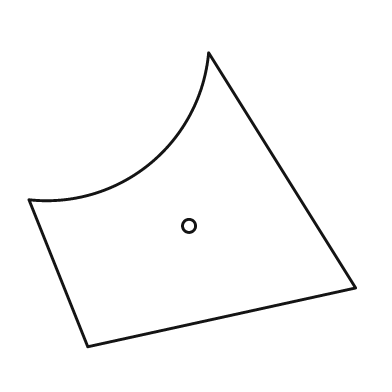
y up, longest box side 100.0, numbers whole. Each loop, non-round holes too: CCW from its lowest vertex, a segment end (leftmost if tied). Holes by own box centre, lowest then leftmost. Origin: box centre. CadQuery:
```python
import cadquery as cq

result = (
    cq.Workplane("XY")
    .moveTo(-32.0, -45.0)
    .lineTo(50.0, -27.0)
    .lineTo(5.0, 45.0)
    .threePointArc((-13.0, 11.0), (-50.0, 0.0))
    .close()
    .moveTo(-1.0, -8.0)
    .circle(2.0)
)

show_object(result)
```